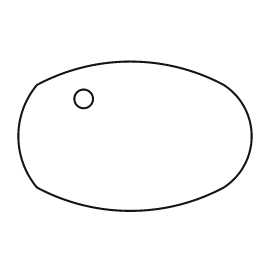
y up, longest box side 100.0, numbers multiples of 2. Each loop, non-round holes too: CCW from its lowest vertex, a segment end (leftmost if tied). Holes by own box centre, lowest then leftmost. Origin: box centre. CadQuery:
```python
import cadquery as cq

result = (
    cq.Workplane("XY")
    .moveTo(-42.0, -22.0)
    .threePointArc((-2.0, -32.0), (38.0, -22.0))
    .threePointArc((50.0, 0.0), (38.0, 22.0))
    .threePointArc((-2.0, 32.0), (-42.0, 22.0))
    .threePointArc((-50.0, 0.0), (-42.0, -22.0))
    .close()
    .moveTo(-22.0, 16.0)
    .circle(4.0)
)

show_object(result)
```